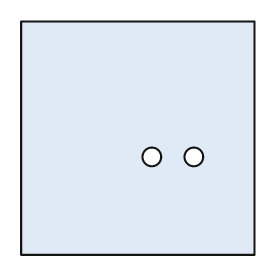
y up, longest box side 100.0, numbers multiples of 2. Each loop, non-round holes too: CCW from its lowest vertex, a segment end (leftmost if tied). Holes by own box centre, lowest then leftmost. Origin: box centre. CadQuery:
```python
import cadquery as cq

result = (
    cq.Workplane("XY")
    .moveTo(-50.0, -50.0)
    .lineTo(50.0, -50.0)
    .lineTo(50.0, 50.0)
    .lineTo(-50.0, 50.0)
    .close()
    .moveTo(6.0, -8.0)
    .circle(4.0)
    .moveTo(24.0, -8.0)
    .circle(4.0)
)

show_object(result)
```